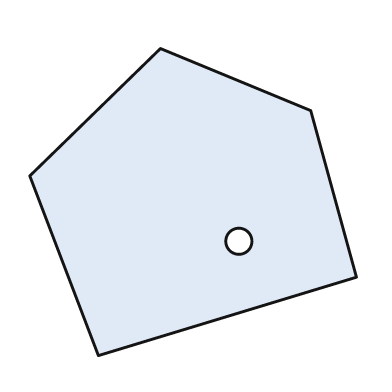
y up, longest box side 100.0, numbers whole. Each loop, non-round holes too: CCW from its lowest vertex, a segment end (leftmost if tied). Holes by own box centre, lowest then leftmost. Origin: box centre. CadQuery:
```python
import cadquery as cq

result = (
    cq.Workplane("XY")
    .moveTo(-29.0, -47.0)
    .lineTo(50.0, -23.0)
    .lineTo(36.0, 28.0)
    .lineTo(-10.0, 47.0)
    .lineTo(-50.0, 8.0)
    .close()
    .moveTo(14.0, -12.0)
    .circle(4.0)
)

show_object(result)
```